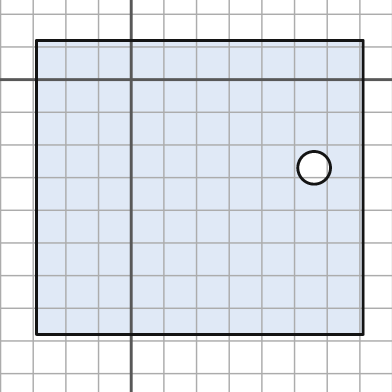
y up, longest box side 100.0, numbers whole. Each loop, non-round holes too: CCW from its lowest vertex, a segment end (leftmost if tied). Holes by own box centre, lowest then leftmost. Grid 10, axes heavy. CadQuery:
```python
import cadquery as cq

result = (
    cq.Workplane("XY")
    .moveTo(-29.0, -78.0)
    .lineTo(71.0, -78.0)
    .lineTo(71.0, 12.0)
    .lineTo(-29.0, 12.0)
    .close()
    .moveTo(56.0, -27.0)
    .circle(5.0)
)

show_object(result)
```